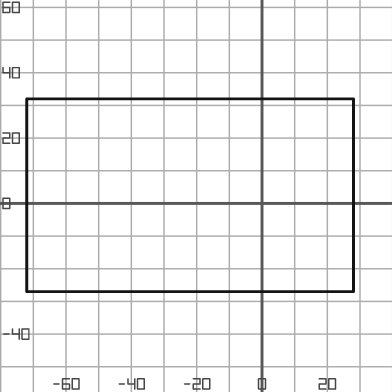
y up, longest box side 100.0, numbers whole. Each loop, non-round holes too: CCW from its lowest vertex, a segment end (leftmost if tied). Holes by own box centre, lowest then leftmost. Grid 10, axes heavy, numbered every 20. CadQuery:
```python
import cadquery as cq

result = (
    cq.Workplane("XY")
    .moveTo(-72.0, -27.0)
    .lineTo(28.0, -27.0)
    .lineTo(28.0, 32.0)
    .lineTo(-72.0, 32.0)
    .close()
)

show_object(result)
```